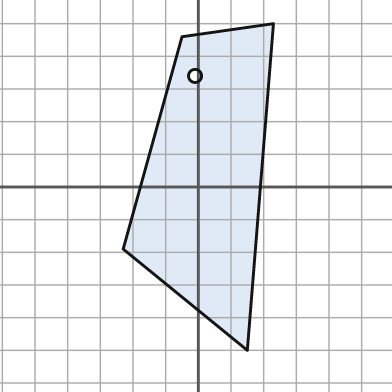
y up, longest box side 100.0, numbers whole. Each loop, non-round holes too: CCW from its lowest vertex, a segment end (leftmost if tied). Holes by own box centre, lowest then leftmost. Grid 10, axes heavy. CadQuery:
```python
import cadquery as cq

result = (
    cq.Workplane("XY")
    .moveTo(15.0, -50.0)
    .lineTo(23.0, 50.0)
    .lineTo(-5.0, 46.0)
    .lineTo(-23.0, -19.0)
    .close()
    .moveTo(-1.0, 34.0)
    .circle(2.0)
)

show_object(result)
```